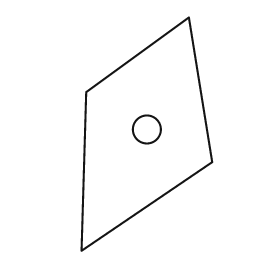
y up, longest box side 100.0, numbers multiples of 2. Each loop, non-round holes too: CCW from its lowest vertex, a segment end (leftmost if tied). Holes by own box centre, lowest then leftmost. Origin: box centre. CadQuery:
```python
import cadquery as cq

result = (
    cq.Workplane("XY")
    .moveTo(-28.0, -50.0)
    .lineTo(28.0, -12.0)
    .lineTo(18.0, 50.0)
    .lineTo(-26.0, 18.0)
    .close()
    .moveTo(0.0, 2.0)
    .circle(6.0)
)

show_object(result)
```